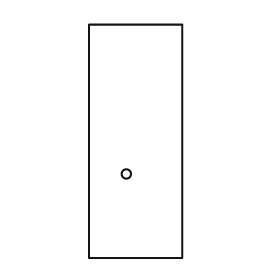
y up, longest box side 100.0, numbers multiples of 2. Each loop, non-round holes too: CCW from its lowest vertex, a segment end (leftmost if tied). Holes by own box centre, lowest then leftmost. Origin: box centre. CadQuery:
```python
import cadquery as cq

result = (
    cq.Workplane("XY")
    .moveTo(-20.0, -50.0)
    .lineTo(20.0, -50.0)
    .lineTo(20.0, 50.0)
    .lineTo(-20.0, 50.0)
    .close()
    .moveTo(-4.0, -14.0)
    .circle(2.0)
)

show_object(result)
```